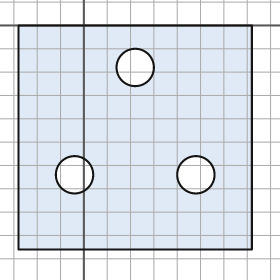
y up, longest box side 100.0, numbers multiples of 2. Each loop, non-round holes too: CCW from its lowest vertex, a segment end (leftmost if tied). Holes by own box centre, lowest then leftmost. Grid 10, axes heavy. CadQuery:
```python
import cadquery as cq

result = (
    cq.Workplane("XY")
    .moveTo(-28.0, -96.0)
    .lineTo(72.0, -96.0)
    .lineTo(72.0, 0.0)
    .lineTo(-28.0, 0.0)
    .close()
    .moveTo(-4.0, -64.0)
    .circle(8.0)
    .moveTo(48.0, -64.0)
    .circle(8.0)
    .moveTo(22.0, -18.0)
    .circle(8.0)
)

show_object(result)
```